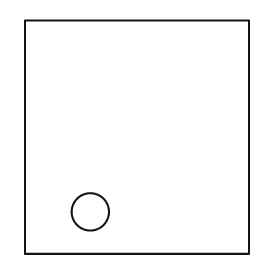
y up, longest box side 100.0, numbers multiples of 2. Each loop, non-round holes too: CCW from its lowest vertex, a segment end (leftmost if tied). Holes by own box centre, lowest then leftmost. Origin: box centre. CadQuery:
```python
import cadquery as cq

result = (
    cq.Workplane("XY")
    .moveTo(-48.0, -50.0)
    .lineTo(48.0, -50.0)
    .lineTo(48.0, 50.0)
    .lineTo(-48.0, 50.0)
    .close()
    .moveTo(-20.0, -32.0)
    .circle(8.0)
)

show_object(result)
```